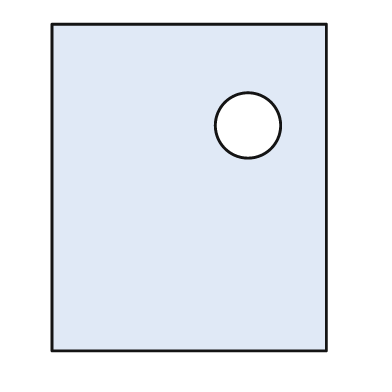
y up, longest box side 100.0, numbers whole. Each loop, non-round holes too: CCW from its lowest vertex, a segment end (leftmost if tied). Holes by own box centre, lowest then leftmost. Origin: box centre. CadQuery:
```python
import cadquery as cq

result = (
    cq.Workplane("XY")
    .moveTo(-42.0, -50.0)
    .lineTo(42.0, -50.0)
    .lineTo(42.0, 50.0)
    .lineTo(-42.0, 50.0)
    .close()
    .moveTo(18.0, 19.0)
    .circle(10.0)
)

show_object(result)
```